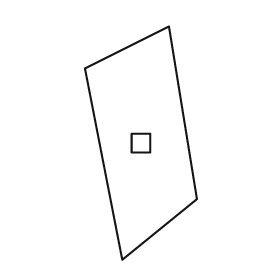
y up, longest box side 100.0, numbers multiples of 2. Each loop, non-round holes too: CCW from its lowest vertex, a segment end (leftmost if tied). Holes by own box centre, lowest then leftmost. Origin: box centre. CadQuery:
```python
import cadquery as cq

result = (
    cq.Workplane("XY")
    .moveTo(-8.0, -50.0)
    .lineTo(24.0, -24.0)
    .lineTo(12.0, 50.0)
    .lineTo(-24.0, 32.0)
    .close()
    .moveTo(-4.0, -4.0)
    .lineTo(4.0, -4.0)
    .lineTo(4.0, 4.0)
    .lineTo(-4.0, 4.0)
    .close()
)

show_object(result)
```